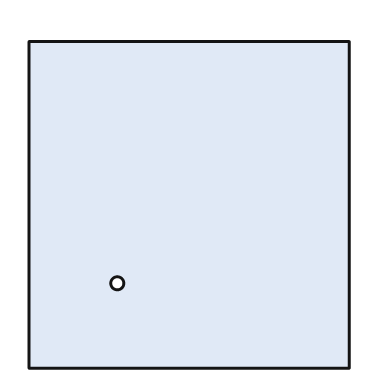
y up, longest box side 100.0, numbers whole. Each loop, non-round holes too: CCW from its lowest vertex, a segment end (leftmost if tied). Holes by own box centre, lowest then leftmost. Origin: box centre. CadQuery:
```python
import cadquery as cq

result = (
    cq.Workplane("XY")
    .moveTo(-49.0, -50.0)
    .lineTo(49.0, -50.0)
    .lineTo(49.0, 50.0)
    .lineTo(-49.0, 50.0)
    .close()
    .moveTo(-22.0, -24.0)
    .circle(2.0)
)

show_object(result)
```